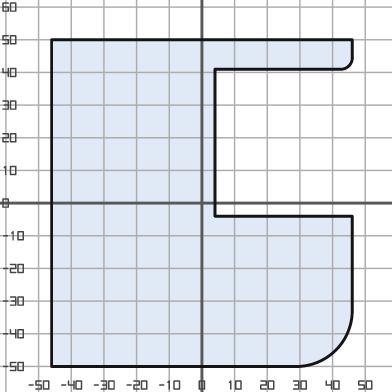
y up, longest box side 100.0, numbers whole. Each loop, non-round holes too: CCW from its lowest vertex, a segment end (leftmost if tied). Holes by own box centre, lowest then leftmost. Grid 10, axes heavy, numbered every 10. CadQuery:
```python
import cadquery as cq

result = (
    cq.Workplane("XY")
    .moveTo(-46.0, -50.0)
    .lineTo(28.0, -50.0)
    .threePointArc((41.0, -45.0), (46.0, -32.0))
    .lineTo(46.0, -4.0)
    .lineTo(4.0, -4.0)
    .lineTo(4.0, 41.0)
    .lineTo(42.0, 41.0)
    .threePointArc((45.0, 42.0), (46.0, 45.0))
    .lineTo(46.0, 50.0)
    .lineTo(-46.0, 50.0)
    .close()
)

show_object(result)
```